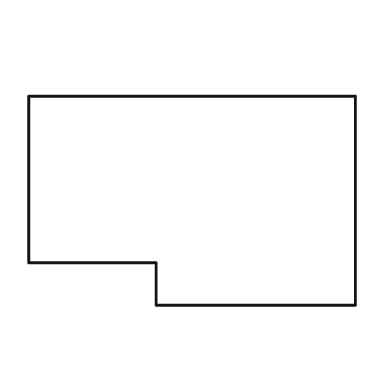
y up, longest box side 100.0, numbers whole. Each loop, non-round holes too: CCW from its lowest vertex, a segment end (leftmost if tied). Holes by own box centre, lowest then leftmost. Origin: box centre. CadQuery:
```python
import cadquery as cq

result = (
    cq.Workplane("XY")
    .moveTo(-11.0, -32.0)
    .lineTo(50.0, -32.0)
    .lineTo(50.0, 32.0)
    .lineTo(-50.0, 32.0)
    .lineTo(-50.0, -19.0)
    .lineTo(-11.0, -19.0)
    .close()
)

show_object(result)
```